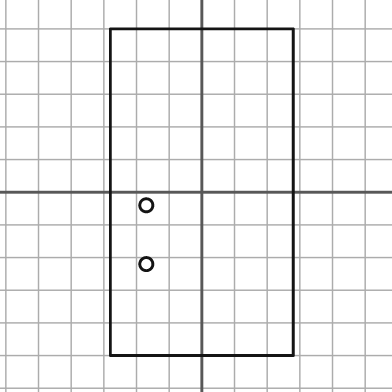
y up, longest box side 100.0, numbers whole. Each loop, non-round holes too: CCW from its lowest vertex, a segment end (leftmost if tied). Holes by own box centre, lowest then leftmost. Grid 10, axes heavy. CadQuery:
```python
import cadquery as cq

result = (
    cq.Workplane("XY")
    .moveTo(-28.0, -50.0)
    .lineTo(28.0, -50.0)
    .lineTo(28.0, 50.0)
    .lineTo(-28.0, 50.0)
    .close()
    .moveTo(-17.0, -22.0)
    .circle(2.0)
    .moveTo(-17.0, -4.0)
    .circle(2.0)
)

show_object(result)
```